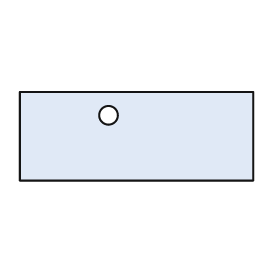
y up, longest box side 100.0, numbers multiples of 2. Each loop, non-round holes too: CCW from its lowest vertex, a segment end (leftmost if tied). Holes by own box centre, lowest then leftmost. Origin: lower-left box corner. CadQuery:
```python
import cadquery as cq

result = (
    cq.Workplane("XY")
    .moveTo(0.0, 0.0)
    .lineTo(100.0, 0.0)
    .lineTo(100.0, 38.0)
    .lineTo(0.0, 38.0)
    .close()
    .moveTo(38.0, 28.0)
    .circle(4.0)
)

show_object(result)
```